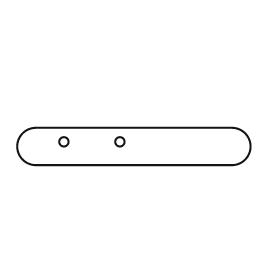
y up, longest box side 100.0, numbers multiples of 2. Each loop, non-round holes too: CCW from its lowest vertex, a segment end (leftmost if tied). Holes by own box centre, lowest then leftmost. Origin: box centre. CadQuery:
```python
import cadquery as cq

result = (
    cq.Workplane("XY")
    .moveTo(-42.0, -8.0)
    .lineTo(42.0, -8.0)
    .threePointArc((50.0, 0.0), (42.0, 8.0))
    .lineTo(-42.0, 8.0)
    .threePointArc((-50.0, 0.0), (-42.0, -8.0))
    .close()
    .moveTo(-30.0, 2.0)
    .circle(2.0)
    .moveTo(-6.0, 2.0)
    .circle(2.0)
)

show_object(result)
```